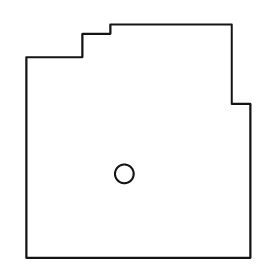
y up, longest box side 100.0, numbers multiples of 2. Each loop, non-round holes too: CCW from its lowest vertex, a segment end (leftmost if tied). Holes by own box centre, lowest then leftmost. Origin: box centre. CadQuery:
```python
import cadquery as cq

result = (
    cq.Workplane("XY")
    .moveTo(-48.0, -50.0)
    .lineTo(48.0, -50.0)
    .lineTo(48.0, 16.0)
    .lineTo(40.0, 16.0)
    .lineTo(40.0, 50.0)
    .lineTo(-12.0, 50.0)
    .lineTo(-12.0, 46.0)
    .lineTo(-24.0, 46.0)
    .lineTo(-24.0, 36.0)
    .lineTo(-48.0, 36.0)
    .close()
    .moveTo(-6.0, -14.0)
    .circle(4.0)
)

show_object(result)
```